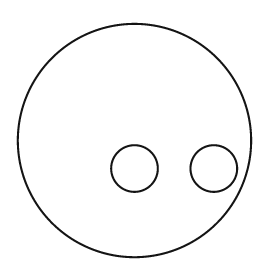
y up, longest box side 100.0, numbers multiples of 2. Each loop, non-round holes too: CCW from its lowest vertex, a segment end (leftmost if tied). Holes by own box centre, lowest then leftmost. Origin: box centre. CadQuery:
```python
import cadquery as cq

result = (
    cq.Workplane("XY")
    .moveTo(0.0, 0.0)
    .circle(50.0)
    .moveTo(0.0, -12.0)
    .circle(10.0)
    .moveTo(34.0, -12.0)
    .circle(10.0)
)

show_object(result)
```